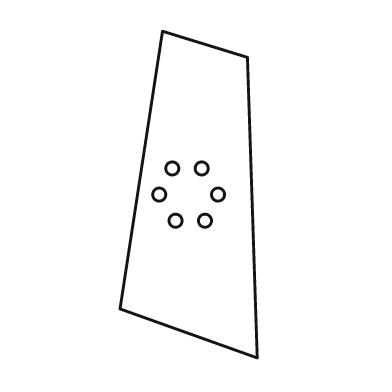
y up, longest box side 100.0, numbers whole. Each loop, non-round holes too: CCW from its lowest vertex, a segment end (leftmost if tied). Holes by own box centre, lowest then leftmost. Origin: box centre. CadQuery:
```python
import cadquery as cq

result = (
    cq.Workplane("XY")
    .moveTo(21.0, -50.0)
    .lineTo(18.0, 42.0)
    .lineTo(-8.0, 50.0)
    .lineTo(-21.0, -35.0)
    .close()
    .moveTo(-4.0, -8.0)
    .circle(2.0)
    .moveTo(5.0, -8.0)
    .circle(2.0)
    .moveTo(-9.0, 0.0)
    .circle(2.0)
    .moveTo(9.0, 0.0)
    .circle(2.0)
    .moveTo(-5.0, 8.0)
    .circle(2.0)
    .moveTo(4.0, 8.0)
    .circle(2.0)
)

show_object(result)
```